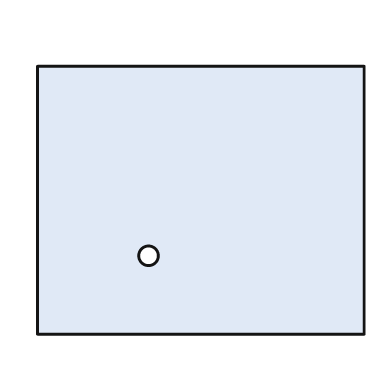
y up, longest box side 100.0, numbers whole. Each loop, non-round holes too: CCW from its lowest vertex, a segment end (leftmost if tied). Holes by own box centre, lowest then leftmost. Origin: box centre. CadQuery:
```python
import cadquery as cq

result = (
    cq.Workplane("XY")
    .moveTo(-50.0, -41.0)
    .lineTo(50.0, -41.0)
    .lineTo(50.0, 41.0)
    .lineTo(-50.0, 41.0)
    .close()
    .moveTo(-16.0, -17.0)
    .circle(3.0)
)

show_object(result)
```